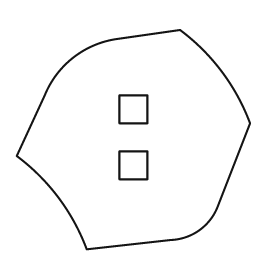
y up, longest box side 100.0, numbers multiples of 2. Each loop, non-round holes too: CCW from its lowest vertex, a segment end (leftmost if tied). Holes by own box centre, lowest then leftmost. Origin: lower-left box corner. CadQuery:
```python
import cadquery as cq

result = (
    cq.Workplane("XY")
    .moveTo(30.0, 0.0)
    .lineTo(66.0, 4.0)
    .threePointArc((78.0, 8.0), (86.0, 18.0))
    .lineTo(100.0, 54.0)
    .threePointArc((88.0, 76.0), (70.0, 94.0))
    .lineTo(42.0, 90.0)
    .threePointArc((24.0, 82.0), (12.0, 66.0))
    .lineTo(0.0, 40.0)
    .threePointArc((18.0, 22.0), (30.0, 0.0))
    .close()
    .moveTo(44.0, 30.0)
    .lineTo(56.0, 30.0)
    .lineTo(56.0, 42.0)
    .lineTo(44.0, 42.0)
    .close()
    .moveTo(44.0, 54.0)
    .lineTo(56.0, 54.0)
    .lineTo(56.0, 66.0)
    .lineTo(44.0, 66.0)
    .close()
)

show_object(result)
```